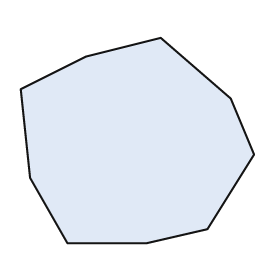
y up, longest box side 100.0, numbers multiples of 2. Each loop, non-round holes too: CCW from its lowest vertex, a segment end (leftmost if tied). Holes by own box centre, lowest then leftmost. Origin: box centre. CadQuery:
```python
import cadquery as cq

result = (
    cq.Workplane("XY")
    .moveTo(-30.0, -44.0)
    .lineTo(4.0, -44.0)
    .lineTo(30.0, -38.0)
    .lineTo(50.0, -6.0)
    .lineTo(40.0, 18.0)
    .lineTo(10.0, 44.0)
    .lineTo(-22.0, 36.0)
    .lineTo(-50.0, 22.0)
    .lineTo(-46.0, -16.0)
    .close()
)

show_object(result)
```